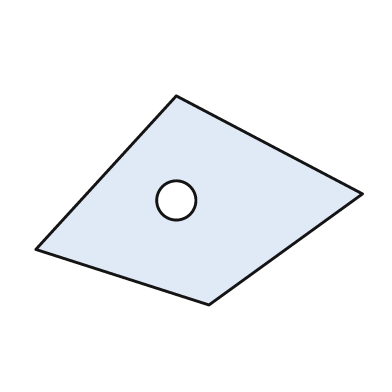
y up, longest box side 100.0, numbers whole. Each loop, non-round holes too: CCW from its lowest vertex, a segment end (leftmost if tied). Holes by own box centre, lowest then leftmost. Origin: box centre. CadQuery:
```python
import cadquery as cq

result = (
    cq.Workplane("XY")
    .moveTo(3.0, -32.0)
    .lineTo(50.0, 2.0)
    .lineTo(-7.0, 32.0)
    .lineTo(-50.0, -15.0)
    .close()
    .moveTo(-7.0, 0.0)
    .circle(6.0)
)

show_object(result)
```